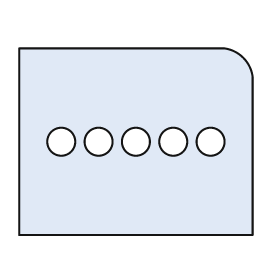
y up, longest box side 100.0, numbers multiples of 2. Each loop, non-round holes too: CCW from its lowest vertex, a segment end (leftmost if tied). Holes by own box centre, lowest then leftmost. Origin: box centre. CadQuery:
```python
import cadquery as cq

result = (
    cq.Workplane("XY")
    .moveTo(-50.0, -40.0)
    .lineTo(50.0, -40.0)
    .lineTo(50.0, 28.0)
    .threePointArc((46.0, 36.0), (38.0, 40.0))
    .lineTo(-50.0, 40.0)
    .close()
    .moveTo(-32.0, 0.0)
    .circle(6.0)
    .moveTo(-16.0, 0.0)
    .circle(6.0)
    .moveTo(0.0, 0.0)
    .circle(6.0)
    .moveTo(16.0, 0.0)
    .circle(6.0)
    .moveTo(32.0, 0.0)
    .circle(6.0)
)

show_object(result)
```